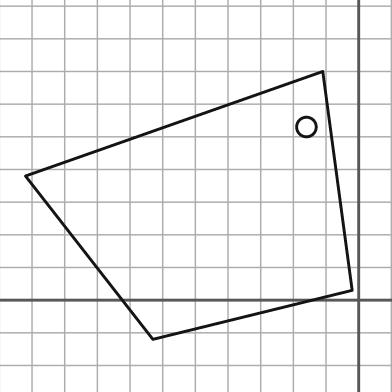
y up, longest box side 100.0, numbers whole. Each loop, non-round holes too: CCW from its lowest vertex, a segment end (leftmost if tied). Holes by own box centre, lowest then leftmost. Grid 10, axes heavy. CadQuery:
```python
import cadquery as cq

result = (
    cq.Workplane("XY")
    .moveTo(-63.0, -12.0)
    .lineTo(-2.0, 3.0)
    .lineTo(-11.0, 70.0)
    .lineTo(-102.0, 38.0)
    .close()
    .moveTo(-16.0, 53.0)
    .circle(3.0)
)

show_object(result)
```